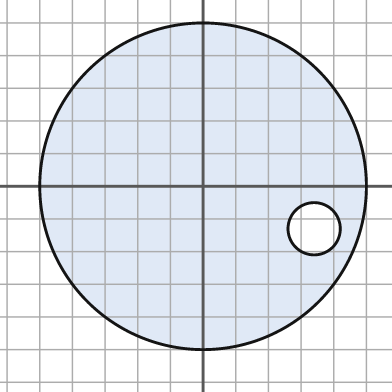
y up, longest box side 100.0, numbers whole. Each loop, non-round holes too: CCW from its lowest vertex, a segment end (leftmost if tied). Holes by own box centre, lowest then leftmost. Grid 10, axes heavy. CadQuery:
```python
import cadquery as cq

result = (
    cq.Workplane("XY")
    .moveTo(0.0, 0.0)
    .circle(50.0)
    .moveTo(34.0, -13.0)
    .circle(8.0)
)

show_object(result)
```